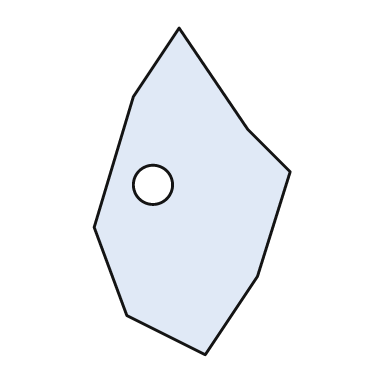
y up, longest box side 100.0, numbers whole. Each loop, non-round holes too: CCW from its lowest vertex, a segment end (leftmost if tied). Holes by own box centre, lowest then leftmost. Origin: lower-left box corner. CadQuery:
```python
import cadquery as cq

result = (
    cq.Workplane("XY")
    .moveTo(34.0, 0.0)
    .lineTo(50.0, 24.0)
    .lineTo(60.0, 56.0)
    .lineTo(47.0, 69.0)
    .lineTo(26.0, 100.0)
    .lineTo(12.0, 79.0)
    .lineTo(0.0, 39.0)
    .lineTo(10.0, 12.0)
    .close()
    .moveTo(18.0, 52.0)
    .circle(6.0)
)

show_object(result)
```